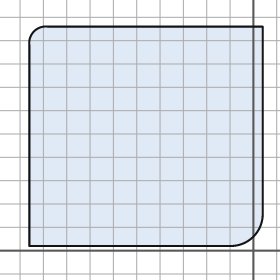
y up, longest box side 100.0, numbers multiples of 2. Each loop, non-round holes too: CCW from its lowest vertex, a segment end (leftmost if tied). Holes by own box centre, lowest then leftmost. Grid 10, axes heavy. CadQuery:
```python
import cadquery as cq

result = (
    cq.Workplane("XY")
    .moveTo(-96.0, 2.0)
    .lineTo(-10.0, 2.0)
    .threePointArc((0.0, 6.0), (4.0, 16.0))
    .lineTo(4.0, 96.0)
    .lineTo(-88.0, 96.0)
    .threePointArc((-94.0, 94.0), (-96.0, 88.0))
    .close()
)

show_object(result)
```